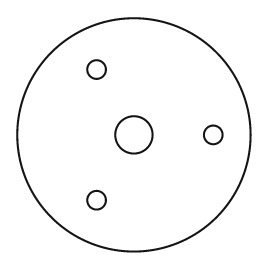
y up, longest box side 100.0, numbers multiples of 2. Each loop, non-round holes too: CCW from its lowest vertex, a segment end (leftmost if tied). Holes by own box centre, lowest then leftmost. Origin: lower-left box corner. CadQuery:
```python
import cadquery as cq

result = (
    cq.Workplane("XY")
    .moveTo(50.0, 50.0)
    .circle(50.0)
    .moveTo(34.0, 22.0)
    .circle(4.0)
    .moveTo(50.0, 50.0)
    .circle(8.0)
    .moveTo(84.0, 50.0)
    .circle(4.0)
    .moveTo(34.0, 78.0)
    .circle(4.0)
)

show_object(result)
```